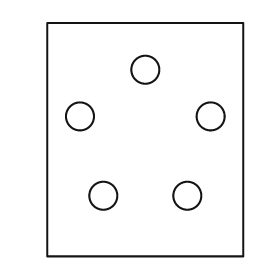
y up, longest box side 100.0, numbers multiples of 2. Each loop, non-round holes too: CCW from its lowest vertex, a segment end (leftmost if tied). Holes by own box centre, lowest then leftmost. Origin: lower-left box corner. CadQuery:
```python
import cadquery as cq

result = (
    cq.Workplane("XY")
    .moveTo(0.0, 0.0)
    .lineTo(84.0, 0.0)
    .lineTo(84.0, 100.0)
    .lineTo(0.0, 100.0)
    .close()
    .moveTo(24.0, 26.0)
    .circle(6.0)
    .moveTo(60.0, 26.0)
    .circle(6.0)
    .moveTo(14.0, 60.0)
    .circle(6.0)
    .moveTo(70.0, 60.0)
    .circle(6.0)
    .moveTo(42.0, 80.0)
    .circle(6.0)
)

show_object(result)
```